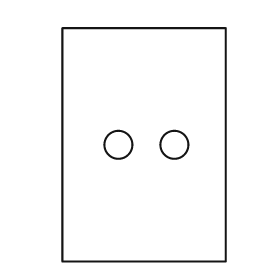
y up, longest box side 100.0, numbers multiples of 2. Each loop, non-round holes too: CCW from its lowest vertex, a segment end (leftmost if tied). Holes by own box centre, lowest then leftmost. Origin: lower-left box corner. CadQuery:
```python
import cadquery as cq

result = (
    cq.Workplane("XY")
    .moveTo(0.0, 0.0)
    .lineTo(70.0, 0.0)
    .lineTo(70.0, 100.0)
    .lineTo(0.0, 100.0)
    .close()
    .moveTo(24.0, 50.0)
    .circle(6.0)
    .moveTo(48.0, 50.0)
    .circle(6.0)
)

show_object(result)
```